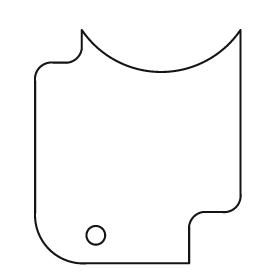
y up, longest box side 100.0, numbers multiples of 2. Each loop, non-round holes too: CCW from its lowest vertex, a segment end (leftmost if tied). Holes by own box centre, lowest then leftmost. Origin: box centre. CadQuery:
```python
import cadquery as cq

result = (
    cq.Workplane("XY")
    .moveTo(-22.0, -50.0)
    .lineTo(22.0, -50.0)
    .lineTo(22.0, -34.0)
    .threePointArc((24.0, -30.0), (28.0, -28.0))
    .lineTo(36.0, -28.0)
    .threePointArc((42.0, -26.0), (44.0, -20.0))
    .lineTo(44.0, 50.0)
    .threePointArc((10.0, 32.0), (-24.0, 50.0))
    .lineTo(-24.0, 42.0)
    .threePointArc((-26.0, 38.0), (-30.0, 36.0))
    .lineTo(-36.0, 36.0)
    .threePointArc((-42.0, 34.0), (-44.0, 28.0))
    .lineTo(-44.0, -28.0)
    .threePointArc((-38.0, -44.0), (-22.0, -50.0))
    .close()
    .moveTo(-18.0, -38.0)
    .circle(4.0)
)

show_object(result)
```